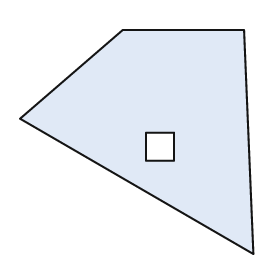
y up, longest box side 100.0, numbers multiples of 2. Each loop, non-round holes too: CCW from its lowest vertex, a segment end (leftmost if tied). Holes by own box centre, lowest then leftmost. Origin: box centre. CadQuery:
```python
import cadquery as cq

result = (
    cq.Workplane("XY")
    .moveTo(50.0, -48.0)
    .lineTo(46.0, 48.0)
    .lineTo(-6.0, 48.0)
    .lineTo(-50.0, 10.0)
    .close()
    .moveTo(4.0, -8.0)
    .lineTo(16.0, -8.0)
    .lineTo(16.0, 4.0)
    .lineTo(4.0, 4.0)
    .close()
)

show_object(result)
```